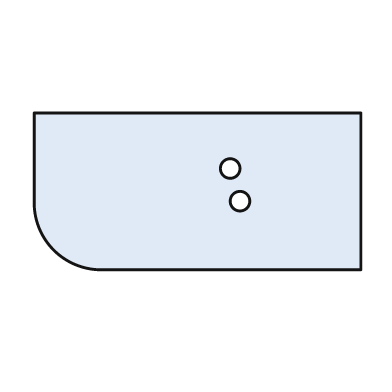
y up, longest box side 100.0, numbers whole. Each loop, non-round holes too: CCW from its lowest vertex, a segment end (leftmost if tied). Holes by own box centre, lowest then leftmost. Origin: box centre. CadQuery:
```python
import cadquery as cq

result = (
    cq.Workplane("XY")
    .moveTo(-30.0, -24.0)
    .lineTo(50.0, -24.0)
    .lineTo(50.0, 24.0)
    .lineTo(-50.0, 24.0)
    .lineTo(-50.0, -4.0)
    .threePointArc((-44.0, -18.0), (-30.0, -24.0))
    .close()
    .moveTo(13.0, -3.0)
    .circle(3.0)
    .moveTo(10.0, 7.0)
    .circle(3.0)
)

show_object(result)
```